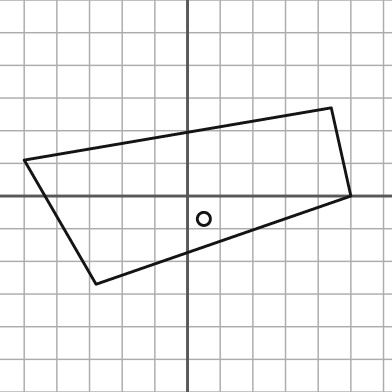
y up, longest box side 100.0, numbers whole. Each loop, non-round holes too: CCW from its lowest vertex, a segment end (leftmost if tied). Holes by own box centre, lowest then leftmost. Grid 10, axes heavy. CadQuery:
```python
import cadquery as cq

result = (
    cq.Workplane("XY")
    .moveTo(-28.0, -27.0)
    .lineTo(50.0, 0.0)
    .lineTo(44.0, 27.0)
    .lineTo(-50.0, 11.0)
    .close()
    .moveTo(5.0, -7.0)
    .circle(2.0)
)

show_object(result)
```